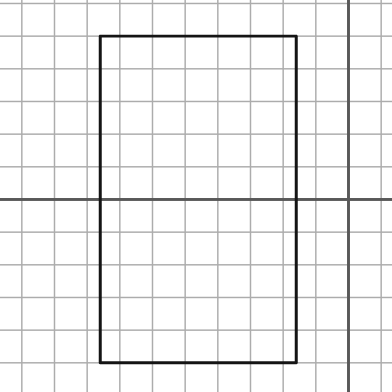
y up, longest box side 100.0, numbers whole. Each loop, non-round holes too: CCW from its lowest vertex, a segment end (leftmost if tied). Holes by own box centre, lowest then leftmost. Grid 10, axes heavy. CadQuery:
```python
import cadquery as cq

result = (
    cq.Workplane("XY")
    .moveTo(-76.0, -50.0)
    .lineTo(-16.0, -50.0)
    .lineTo(-16.0, 50.0)
    .lineTo(-76.0, 50.0)
    .close()
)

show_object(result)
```